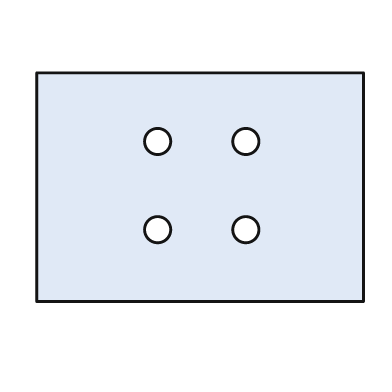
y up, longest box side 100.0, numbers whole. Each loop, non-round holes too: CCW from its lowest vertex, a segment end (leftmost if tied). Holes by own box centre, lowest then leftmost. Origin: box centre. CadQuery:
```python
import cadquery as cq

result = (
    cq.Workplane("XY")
    .moveTo(-50.0, -35.0)
    .lineTo(50.0, -35.0)
    .lineTo(50.0, 35.0)
    .lineTo(-50.0, 35.0)
    .close()
    .moveTo(-13.0, -13.0)
    .circle(4.0)
    .moveTo(14.0, -13.0)
    .circle(4.0)
    .moveTo(-13.0, 14.0)
    .circle(4.0)
    .moveTo(14.0, 14.0)
    .circle(4.0)
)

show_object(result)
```